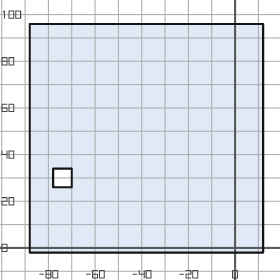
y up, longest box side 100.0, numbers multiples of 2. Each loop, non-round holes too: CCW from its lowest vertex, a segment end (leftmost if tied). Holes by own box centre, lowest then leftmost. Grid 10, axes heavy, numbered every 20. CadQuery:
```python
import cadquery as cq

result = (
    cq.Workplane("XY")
    .moveTo(-88.0, -2.0)
    .lineTo(12.0, -2.0)
    .lineTo(12.0, 96.0)
    .lineTo(-88.0, 96.0)
    .close()
    .moveTo(-78.0, 26.0)
    .lineTo(-70.0, 26.0)
    .lineTo(-70.0, 34.0)
    .lineTo(-78.0, 34.0)
    .close()
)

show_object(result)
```